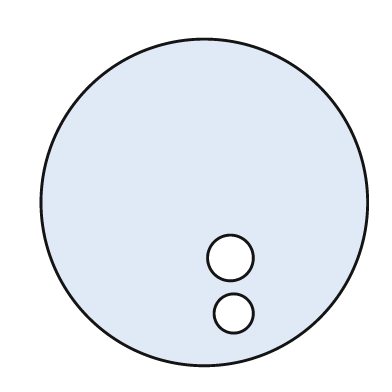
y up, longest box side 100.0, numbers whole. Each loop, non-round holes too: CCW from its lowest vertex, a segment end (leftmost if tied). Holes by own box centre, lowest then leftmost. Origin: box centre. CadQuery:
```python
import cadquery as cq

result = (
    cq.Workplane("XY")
    .moveTo(0.0, 0.0)
    .circle(50.0)
    .moveTo(9.0, -34.0)
    .circle(6.0)
    .moveTo(8.0, -17.0)
    .circle(7.0)
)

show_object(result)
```